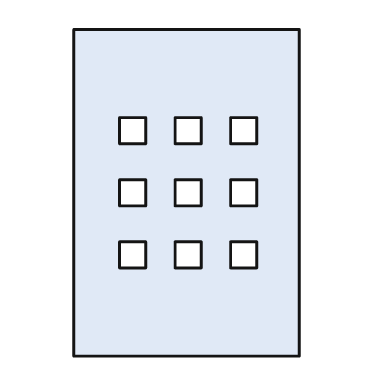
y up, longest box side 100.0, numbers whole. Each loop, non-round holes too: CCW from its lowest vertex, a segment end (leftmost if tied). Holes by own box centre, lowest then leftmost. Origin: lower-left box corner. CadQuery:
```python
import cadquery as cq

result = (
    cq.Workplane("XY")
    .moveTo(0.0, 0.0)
    .lineTo(69.0, 0.0)
    .lineTo(69.0, 100.0)
    .lineTo(0.0, 100.0)
    .close()
    .moveTo(14.0, 27.0)
    .lineTo(22.0, 27.0)
    .lineTo(22.0, 35.0)
    .lineTo(14.0, 35.0)
    .close()
    .moveTo(31.0, 27.0)
    .lineTo(39.0, 27.0)
    .lineTo(39.0, 35.0)
    .lineTo(31.0, 35.0)
    .close()
    .moveTo(48.0, 27.0)
    .lineTo(56.0, 27.0)
    .lineTo(56.0, 35.0)
    .lineTo(48.0, 35.0)
    .close()
    .moveTo(14.0, 46.0)
    .lineTo(22.0, 46.0)
    .lineTo(22.0, 54.0)
    .lineTo(14.0, 54.0)
    .close()
    .moveTo(31.0, 46.0)
    .lineTo(39.0, 46.0)
    .lineTo(39.0, 54.0)
    .lineTo(31.0, 54.0)
    .close()
    .moveTo(48.0, 46.0)
    .lineTo(56.0, 46.0)
    .lineTo(56.0, 54.0)
    .lineTo(48.0, 54.0)
    .close()
    .moveTo(14.0, 65.0)
    .lineTo(22.0, 65.0)
    .lineTo(22.0, 73.0)
    .lineTo(14.0, 73.0)
    .close()
    .moveTo(31.0, 65.0)
    .lineTo(39.0, 65.0)
    .lineTo(39.0, 73.0)
    .lineTo(31.0, 73.0)
    .close()
    .moveTo(48.0, 65.0)
    .lineTo(56.0, 65.0)
    .lineTo(56.0, 73.0)
    .lineTo(48.0, 73.0)
    .close()
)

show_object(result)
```